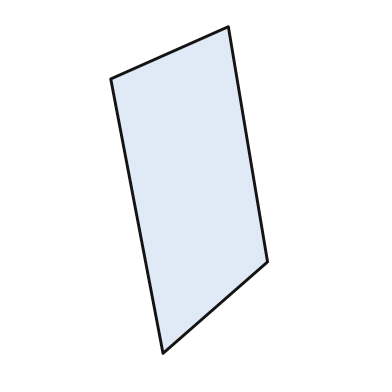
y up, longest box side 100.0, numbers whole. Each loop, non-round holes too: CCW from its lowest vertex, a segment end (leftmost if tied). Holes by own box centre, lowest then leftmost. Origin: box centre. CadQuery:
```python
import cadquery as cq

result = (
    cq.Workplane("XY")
    .moveTo(-8.0, -50.0)
    .lineTo(24.0, -22.0)
    .lineTo(12.0, 50.0)
    .lineTo(-24.0, 34.0)
    .close()
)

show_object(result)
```